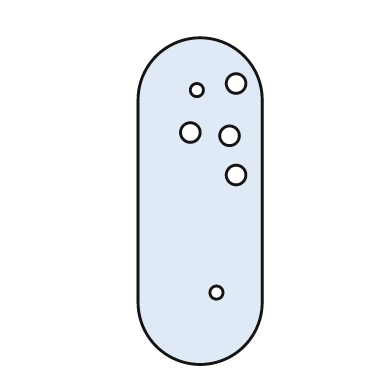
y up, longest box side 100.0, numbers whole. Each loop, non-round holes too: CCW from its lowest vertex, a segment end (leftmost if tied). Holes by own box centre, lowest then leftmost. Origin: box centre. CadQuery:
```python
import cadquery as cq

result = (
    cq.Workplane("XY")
    .moveTo(-19.0, -31.0)
    .threePointArc((0.0, -50.0), (19.0, -31.0))
    .lineTo(19.0, 31.0)
    .threePointArc((0.0, 50.0), (-19.0, 31.0))
    .close()
    .moveTo(5.0, -28.0)
    .circle(2.0)
    .moveTo(11.0, 8.0)
    .circle(3.0)
    .moveTo(9.0, 20.0)
    .circle(3.0)
    .moveTo(-3.0, 21.0)
    .circle(3.0)
    .moveTo(-1.0, 34.0)
    .circle(2.0)
    .moveTo(11.0, 36.0)
    .circle(3.0)
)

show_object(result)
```